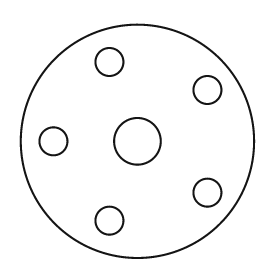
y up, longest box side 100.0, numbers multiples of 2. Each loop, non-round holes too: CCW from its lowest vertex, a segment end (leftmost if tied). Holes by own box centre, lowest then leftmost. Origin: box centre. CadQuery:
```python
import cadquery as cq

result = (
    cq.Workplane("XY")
    .moveTo(0.0, 0.0)
    .circle(50.0)
    .moveTo(-12.0, -34.0)
    .circle(6.0)
    .moveTo(30.0, -22.0)
    .circle(6.0)
    .moveTo(-36.0, 0.0)
    .circle(6.0)
    .moveTo(0.0, 0.0)
    .circle(10.0)
    .moveTo(30.0, 22.0)
    .circle(6.0)
    .moveTo(-12.0, 34.0)
    .circle(6.0)
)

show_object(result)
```